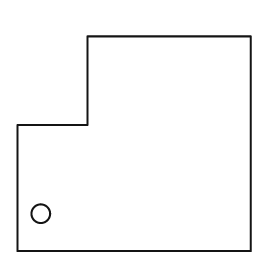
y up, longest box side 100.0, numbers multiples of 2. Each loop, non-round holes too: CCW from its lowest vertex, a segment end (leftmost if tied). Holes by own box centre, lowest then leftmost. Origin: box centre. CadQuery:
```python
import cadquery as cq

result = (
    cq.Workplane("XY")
    .moveTo(-50.0, -46.0)
    .lineTo(50.0, -46.0)
    .lineTo(50.0, 46.0)
    .lineTo(-20.0, 46.0)
    .lineTo(-20.0, 8.0)
    .lineTo(-50.0, 8.0)
    .close()
    .moveTo(-40.0, -30.0)
    .circle(4.0)
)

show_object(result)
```